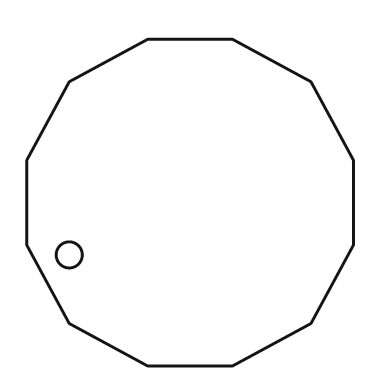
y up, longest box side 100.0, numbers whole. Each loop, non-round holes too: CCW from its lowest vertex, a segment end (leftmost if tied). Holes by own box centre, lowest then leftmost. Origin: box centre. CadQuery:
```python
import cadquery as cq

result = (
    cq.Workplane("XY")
    .moveTo(-13.0, -50.0)
    .lineTo(13.0, -50.0)
    .lineTo(37.0, -37.0)
    .lineTo(50.0, -13.0)
    .lineTo(50.0, 13.0)
    .lineTo(37.0, 37.0)
    .lineTo(13.0, 50.0)
    .lineTo(-13.0, 50.0)
    .lineTo(-37.0, 37.0)
    .lineTo(-50.0, 13.0)
    .lineTo(-50.0, -13.0)
    .lineTo(-37.0, -37.0)
    .close()
    .moveTo(-37.0, -16.0)
    .circle(4.0)
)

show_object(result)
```